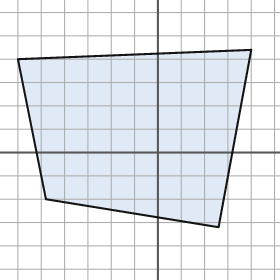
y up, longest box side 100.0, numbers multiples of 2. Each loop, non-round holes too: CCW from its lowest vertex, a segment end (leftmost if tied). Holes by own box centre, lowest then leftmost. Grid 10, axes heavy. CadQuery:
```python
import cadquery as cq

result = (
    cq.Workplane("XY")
    .moveTo(26.0, -32.0)
    .lineTo(40.0, 44.0)
    .lineTo(-60.0, 40.0)
    .lineTo(-48.0, -20.0)
    .close()
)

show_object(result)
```